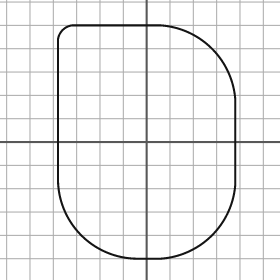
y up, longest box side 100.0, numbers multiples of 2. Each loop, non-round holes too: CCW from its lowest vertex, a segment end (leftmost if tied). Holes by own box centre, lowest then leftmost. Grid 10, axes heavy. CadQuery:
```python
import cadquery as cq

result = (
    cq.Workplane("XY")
    .moveTo(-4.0, -50.0)
    .lineTo(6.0, -50.0)
    .threePointArc((28.0, -40.0), (38.0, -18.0))
    .lineTo(38.0, 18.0)
    .threePointArc((28.0, 40.0), (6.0, 50.0))
    .lineTo(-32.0, 50.0)
    .threePointArc((-36.0, 48.0), (-38.0, 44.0))
    .lineTo(-38.0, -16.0)
    .threePointArc((-28.0, -40.0), (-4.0, -50.0))
    .close()
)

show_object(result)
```